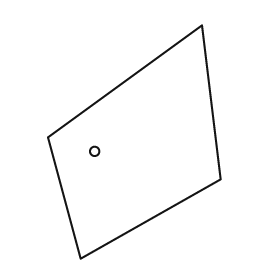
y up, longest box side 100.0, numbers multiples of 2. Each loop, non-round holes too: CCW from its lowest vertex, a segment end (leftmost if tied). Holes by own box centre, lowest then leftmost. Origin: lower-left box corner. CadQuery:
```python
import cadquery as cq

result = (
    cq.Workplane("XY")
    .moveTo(14.0, 0.0)
    .lineTo(74.0, 34.0)
    .lineTo(66.0, 100.0)
    .lineTo(0.0, 52.0)
    .close()
    .moveTo(20.0, 46.0)
    .circle(2.0)
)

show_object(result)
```